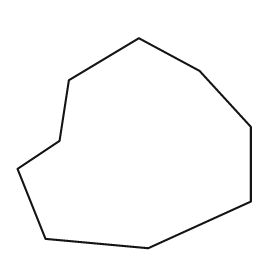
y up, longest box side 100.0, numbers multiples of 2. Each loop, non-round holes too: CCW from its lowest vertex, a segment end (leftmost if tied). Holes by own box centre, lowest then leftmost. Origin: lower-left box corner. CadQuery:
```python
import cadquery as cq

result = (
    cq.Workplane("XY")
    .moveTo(56.0, 0.0)
    .lineTo(100.0, 20.0)
    .lineTo(100.0, 52.0)
    .lineTo(78.0, 76.0)
    .lineTo(52.0, 90.0)
    .lineTo(22.0, 72.0)
    .lineTo(18.0, 46.0)
    .lineTo(0.0, 34.0)
    .lineTo(12.0, 4.0)
    .close()
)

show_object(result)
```